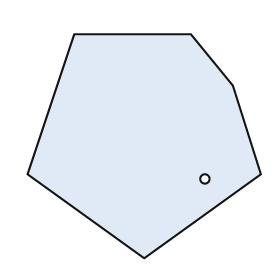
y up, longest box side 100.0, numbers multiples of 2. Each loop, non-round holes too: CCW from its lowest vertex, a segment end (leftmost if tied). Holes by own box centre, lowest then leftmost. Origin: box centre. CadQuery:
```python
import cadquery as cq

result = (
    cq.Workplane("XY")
    .moveTo(0.0, -48.0)
    .lineTo(50.0, -12.0)
    .lineTo(38.0, 26.0)
    .lineTo(20.0, 48.0)
    .lineTo(-30.0, 48.0)
    .lineTo(-50.0, -12.0)
    .close()
    .moveTo(26.0, -14.0)
    .circle(2.0)
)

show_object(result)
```